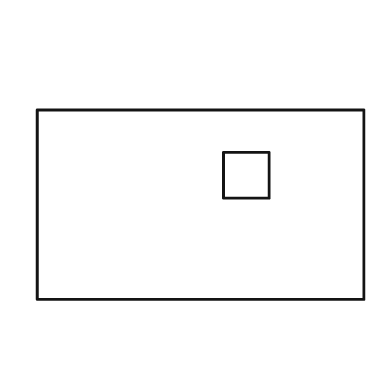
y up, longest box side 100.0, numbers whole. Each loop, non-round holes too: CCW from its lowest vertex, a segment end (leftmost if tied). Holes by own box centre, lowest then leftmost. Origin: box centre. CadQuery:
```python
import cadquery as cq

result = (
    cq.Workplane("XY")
    .moveTo(-50.0, -29.0)
    .lineTo(50.0, -29.0)
    .lineTo(50.0, 29.0)
    .lineTo(-50.0, 29.0)
    .close()
    .moveTo(7.0, 2.0)
    .lineTo(21.0, 2.0)
    .lineTo(21.0, 16.0)
    .lineTo(7.0, 16.0)
    .close()
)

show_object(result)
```